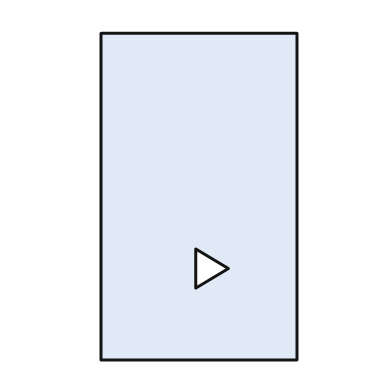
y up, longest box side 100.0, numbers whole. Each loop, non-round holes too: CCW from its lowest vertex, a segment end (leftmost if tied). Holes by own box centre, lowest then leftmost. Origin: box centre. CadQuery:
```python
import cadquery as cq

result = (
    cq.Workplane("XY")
    .moveTo(-30.0, -50.0)
    .lineTo(30.0, -50.0)
    .lineTo(30.0, 50.0)
    .lineTo(-30.0, 50.0)
    .close()
    .moveTo(-1.0, -28.0)
    .lineTo(9.0, -22.0)
    .lineTo(-1.0, -16.0)
    .close()
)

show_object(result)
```